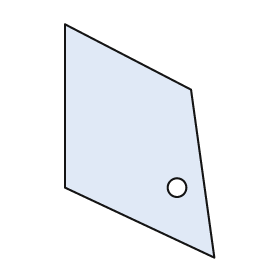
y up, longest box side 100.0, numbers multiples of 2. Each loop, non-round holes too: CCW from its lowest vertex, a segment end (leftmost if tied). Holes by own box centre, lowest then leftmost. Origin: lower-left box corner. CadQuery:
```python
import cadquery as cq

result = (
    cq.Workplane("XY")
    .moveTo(64.0, 0.0)
    .lineTo(54.0, 72.0)
    .lineTo(0.0, 100.0)
    .lineTo(0.0, 30.0)
    .close()
    .moveTo(48.0, 30.0)
    .circle(4.0)
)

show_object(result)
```